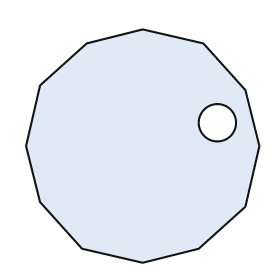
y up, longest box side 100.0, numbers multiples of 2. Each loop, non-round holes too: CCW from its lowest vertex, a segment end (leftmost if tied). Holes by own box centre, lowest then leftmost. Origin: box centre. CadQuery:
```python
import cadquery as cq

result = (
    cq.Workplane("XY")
    .moveTo(0.0, -50.0)
    .lineTo(24.0, -44.0)
    .lineTo(44.0, -26.0)
    .lineTo(50.0, 0.0)
    .lineTo(44.0, 24.0)
    .lineTo(26.0, 44.0)
    .lineTo(0.0, 50.0)
    .lineTo(-24.0, 44.0)
    .lineTo(-44.0, 26.0)
    .lineTo(-50.0, 0.0)
    .lineTo(-44.0, -24.0)
    .lineTo(-26.0, -44.0)
    .close()
    .moveTo(32.0, 10.0)
    .circle(8.0)
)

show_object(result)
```